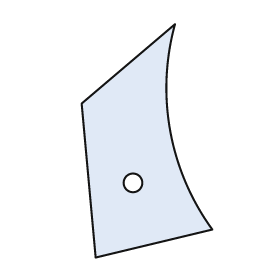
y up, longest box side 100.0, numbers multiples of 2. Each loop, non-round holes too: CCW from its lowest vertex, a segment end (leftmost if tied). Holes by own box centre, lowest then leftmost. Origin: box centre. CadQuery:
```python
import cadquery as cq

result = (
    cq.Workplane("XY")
    .moveTo(-22.0, -50.0)
    .lineTo(28.0, -38.0)
    .threePointArc((10.0, 4.0), (12.0, 50.0))
    .lineTo(-28.0, 16.0)
    .close()
    .moveTo(-6.0, -18.0)
    .circle(4.0)
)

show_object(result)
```